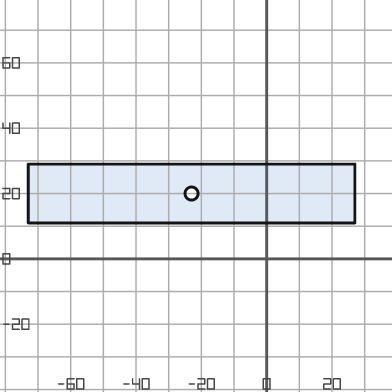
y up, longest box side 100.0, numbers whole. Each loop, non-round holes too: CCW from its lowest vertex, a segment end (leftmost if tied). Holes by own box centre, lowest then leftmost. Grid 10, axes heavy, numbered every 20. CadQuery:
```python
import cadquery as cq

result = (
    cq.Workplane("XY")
    .moveTo(-73.0, 11.0)
    .lineTo(27.0, 11.0)
    .lineTo(27.0, 29.0)
    .lineTo(-73.0, 29.0)
    .close()
    .moveTo(-23.0, 20.0)
    .circle(2.0)
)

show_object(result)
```